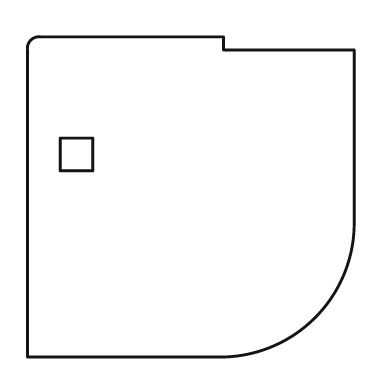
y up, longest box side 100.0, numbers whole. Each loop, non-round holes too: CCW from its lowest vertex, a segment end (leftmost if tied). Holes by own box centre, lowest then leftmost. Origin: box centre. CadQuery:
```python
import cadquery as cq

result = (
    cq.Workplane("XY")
    .moveTo(-50.0, -49.0)
    .lineTo(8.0, -49.0)
    .threePointArc((38.0, -37.0), (50.0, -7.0))
    .lineTo(50.0, 45.0)
    .lineTo(10.0, 45.0)
    .lineTo(10.0, 49.0)
    .lineTo(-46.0, 49.0)
    .threePointArc((-49.0, 48.0), (-50.0, 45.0))
    .close()
    .moveTo(-40.0, 8.0)
    .lineTo(-30.0, 8.0)
    .lineTo(-30.0, 18.0)
    .lineTo(-40.0, 18.0)
    .close()
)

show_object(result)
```